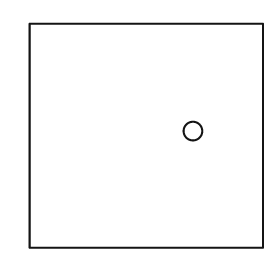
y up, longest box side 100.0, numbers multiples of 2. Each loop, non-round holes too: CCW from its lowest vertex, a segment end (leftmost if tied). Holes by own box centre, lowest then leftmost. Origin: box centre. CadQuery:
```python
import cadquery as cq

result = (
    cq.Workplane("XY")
    .moveTo(-50.0, -48.0)
    .lineTo(50.0, -48.0)
    .lineTo(50.0, 48.0)
    .lineTo(-50.0, 48.0)
    .close()
    .moveTo(20.0, 2.0)
    .circle(4.0)
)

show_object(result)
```